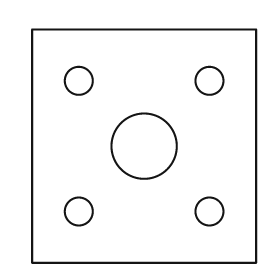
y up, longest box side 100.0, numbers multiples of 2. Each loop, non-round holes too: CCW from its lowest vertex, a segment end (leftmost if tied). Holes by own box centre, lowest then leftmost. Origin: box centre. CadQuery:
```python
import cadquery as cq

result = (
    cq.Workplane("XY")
    .moveTo(-48.0, -50.0)
    .lineTo(48.0, -50.0)
    .lineTo(48.0, 50.0)
    .lineTo(-48.0, 50.0)
    .close()
    .moveTo(-28.0, -28.0)
    .circle(6.0)
    .moveTo(28.0, -28.0)
    .circle(6.0)
    .moveTo(0.0, 0.0)
    .circle(14.0)
    .moveTo(-28.0, 28.0)
    .circle(6.0)
    .moveTo(28.0, 28.0)
    .circle(6.0)
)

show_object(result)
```